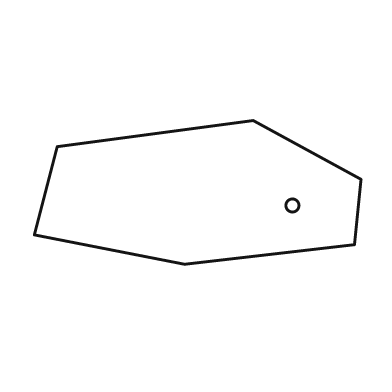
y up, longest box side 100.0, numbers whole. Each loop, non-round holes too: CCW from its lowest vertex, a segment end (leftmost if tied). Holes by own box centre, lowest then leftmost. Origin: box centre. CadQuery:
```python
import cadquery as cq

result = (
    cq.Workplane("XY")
    .moveTo(-4.0, -22.0)
    .lineTo(48.0, -16.0)
    .lineTo(50.0, 4.0)
    .lineTo(17.0, 22.0)
    .lineTo(-43.0, 14.0)
    .lineTo(-50.0, -13.0)
    .close()
    .moveTo(29.0, -4.0)
    .circle(2.0)
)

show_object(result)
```